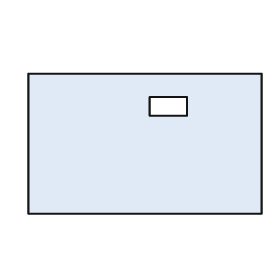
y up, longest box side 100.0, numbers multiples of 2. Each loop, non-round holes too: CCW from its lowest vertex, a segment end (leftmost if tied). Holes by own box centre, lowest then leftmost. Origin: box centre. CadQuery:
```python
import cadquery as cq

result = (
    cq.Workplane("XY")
    .moveTo(-50.0, -30.0)
    .lineTo(50.0, -30.0)
    .lineTo(50.0, 30.0)
    .lineTo(-50.0, 30.0)
    .close()
    .moveTo(2.0, 12.0)
    .lineTo(18.0, 12.0)
    .lineTo(18.0, 20.0)
    .lineTo(2.0, 20.0)
    .close()
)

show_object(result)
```